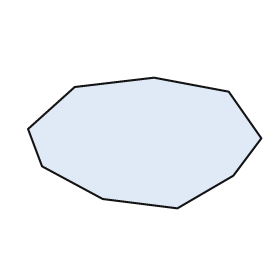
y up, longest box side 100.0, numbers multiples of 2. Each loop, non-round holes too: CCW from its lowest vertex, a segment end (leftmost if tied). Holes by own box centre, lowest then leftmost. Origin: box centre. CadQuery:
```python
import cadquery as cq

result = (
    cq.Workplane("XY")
    .moveTo(14.0, -28.0)
    .lineTo(38.0, -14.0)
    .lineTo(50.0, 2.0)
    .lineTo(36.0, 22.0)
    .lineTo(4.0, 28.0)
    .lineTo(-30.0, 24.0)
    .lineTo(-50.0, 6.0)
    .lineTo(-44.0, -10.0)
    .lineTo(-18.0, -24.0)
    .close()
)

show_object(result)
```